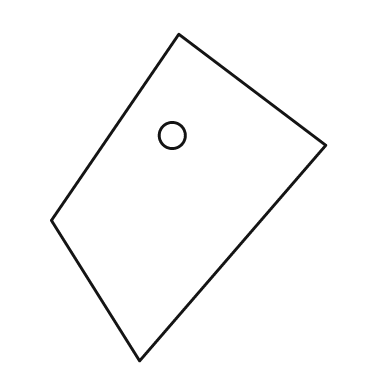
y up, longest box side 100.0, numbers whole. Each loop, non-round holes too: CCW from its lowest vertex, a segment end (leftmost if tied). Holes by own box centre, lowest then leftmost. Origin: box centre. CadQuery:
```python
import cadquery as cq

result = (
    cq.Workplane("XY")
    .moveTo(-15.0, -50.0)
    .lineTo(42.0, 16.0)
    .lineTo(-3.0, 50.0)
    .lineTo(-42.0, -7.0)
    .close()
    .moveTo(-5.0, 19.0)
    .circle(4.0)
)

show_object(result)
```